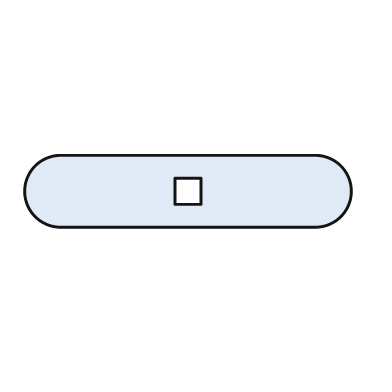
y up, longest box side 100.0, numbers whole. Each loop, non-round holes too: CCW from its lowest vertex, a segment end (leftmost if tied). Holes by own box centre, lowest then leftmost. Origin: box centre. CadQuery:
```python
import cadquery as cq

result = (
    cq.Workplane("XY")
    .moveTo(-39.0, -11.0)
    .lineTo(39.0, -11.0)
    .threePointArc((50.0, 0.0), (39.0, 11.0))
    .lineTo(-39.0, 11.0)
    .threePointArc((-50.0, 0.0), (-39.0, -11.0))
    .close()
    .moveTo(-4.0, -4.0)
    .lineTo(4.0, -4.0)
    .lineTo(4.0, 4.0)
    .lineTo(-4.0, 4.0)
    .close()
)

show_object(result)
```